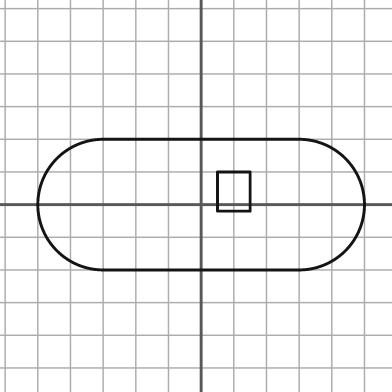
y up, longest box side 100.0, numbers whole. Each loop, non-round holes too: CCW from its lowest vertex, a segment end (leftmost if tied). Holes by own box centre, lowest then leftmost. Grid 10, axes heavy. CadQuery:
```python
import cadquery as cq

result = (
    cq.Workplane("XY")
    .moveTo(-30.0, -20.0)
    .lineTo(30.0, -20.0)
    .threePointArc((50.0, 0.0), (30.0, 20.0))
    .lineTo(-30.0, 20.0)
    .threePointArc((-50.0, 0.0), (-30.0, -20.0))
    .close()
    .moveTo(5.0, -2.0)
    .lineTo(15.0, -2.0)
    .lineTo(15.0, 10.0)
    .lineTo(5.0, 10.0)
    .close()
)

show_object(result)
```